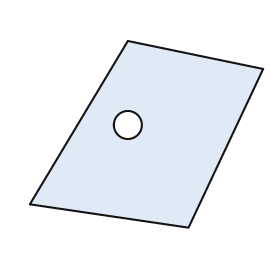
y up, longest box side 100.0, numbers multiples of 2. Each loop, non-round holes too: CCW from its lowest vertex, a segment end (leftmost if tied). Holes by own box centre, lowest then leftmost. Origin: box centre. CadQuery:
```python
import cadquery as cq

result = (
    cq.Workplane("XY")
    .moveTo(18.0, -40.0)
    .lineTo(50.0, 28.0)
    .lineTo(-8.0, 40.0)
    .lineTo(-50.0, -30.0)
    .close()
    .moveTo(-8.0, 4.0)
    .circle(6.0)
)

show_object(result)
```